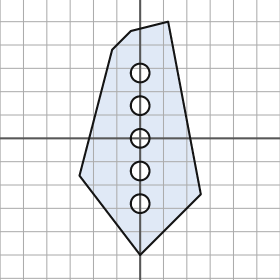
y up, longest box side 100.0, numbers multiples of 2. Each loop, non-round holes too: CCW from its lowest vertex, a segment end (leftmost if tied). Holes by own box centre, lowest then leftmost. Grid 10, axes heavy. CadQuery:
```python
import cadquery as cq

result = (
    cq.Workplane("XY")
    .moveTo(0.0, -50.0)
    .lineTo(26.0, -24.0)
    .lineTo(12.0, 50.0)
    .lineTo(-4.0, 46.0)
    .lineTo(-12.0, 38.0)
    .lineTo(-26.0, -16.0)
    .close()
    .moveTo(0.0, -28.0)
    .circle(4.0)
    .moveTo(0.0, -14.0)
    .circle(4.0)
    .moveTo(0.0, 0.0)
    .circle(4.0)
    .moveTo(0.0, 14.0)
    .circle(4.0)
    .moveTo(0.0, 28.0)
    .circle(4.0)
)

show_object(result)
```